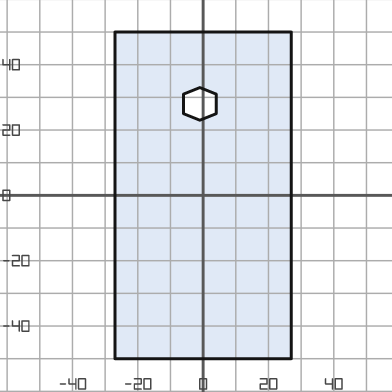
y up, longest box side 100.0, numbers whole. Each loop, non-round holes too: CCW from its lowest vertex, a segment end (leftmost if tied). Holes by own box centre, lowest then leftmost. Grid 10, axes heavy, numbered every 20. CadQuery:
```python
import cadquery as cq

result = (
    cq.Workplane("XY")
    .moveTo(-27.0, -50.0)
    .lineTo(27.0, -50.0)
    .lineTo(27.0, 50.0)
    .lineTo(-27.0, 50.0)
    .close()
    .moveTo(-1.0, 23.0)
    .lineTo(4.0, 25.0)
    .lineTo(4.0, 31.0)
    .lineTo(-1.0, 33.0)
    .lineTo(-6.0, 31.0)
    .lineTo(-6.0, 25.0)
    .close()
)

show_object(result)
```